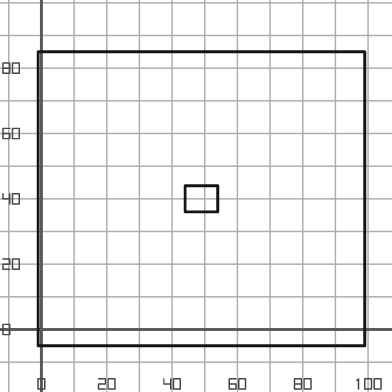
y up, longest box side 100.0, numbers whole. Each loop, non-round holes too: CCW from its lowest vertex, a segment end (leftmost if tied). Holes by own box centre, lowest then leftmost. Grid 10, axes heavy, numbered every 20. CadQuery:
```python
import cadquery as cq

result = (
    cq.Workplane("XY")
    .moveTo(-1.0, -5.0)
    .lineTo(99.0, -5.0)
    .lineTo(99.0, 85.0)
    .lineTo(-1.0, 85.0)
    .close()
    .moveTo(44.0, 36.0)
    .lineTo(54.0, 36.0)
    .lineTo(54.0, 44.0)
    .lineTo(44.0, 44.0)
    .close()
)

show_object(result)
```